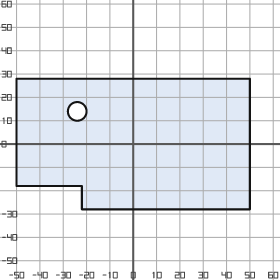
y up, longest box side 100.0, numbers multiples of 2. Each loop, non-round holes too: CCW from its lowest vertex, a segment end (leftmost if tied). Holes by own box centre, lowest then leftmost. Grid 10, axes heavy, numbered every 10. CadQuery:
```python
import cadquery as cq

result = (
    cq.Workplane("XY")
    .moveTo(-22.0, -28.0)
    .lineTo(50.0, -28.0)
    .lineTo(50.0, 28.0)
    .lineTo(-50.0, 28.0)
    .lineTo(-50.0, -18.0)
    .lineTo(-22.0, -18.0)
    .close()
    .moveTo(-24.0, 14.0)
    .circle(4.0)
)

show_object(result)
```